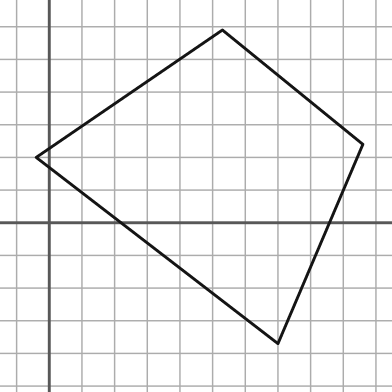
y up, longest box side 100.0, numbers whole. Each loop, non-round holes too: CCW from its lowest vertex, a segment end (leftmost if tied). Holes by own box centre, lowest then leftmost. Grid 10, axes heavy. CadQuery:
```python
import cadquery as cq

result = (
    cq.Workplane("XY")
    .moveTo(70.0, -37.0)
    .lineTo(96.0, 24.0)
    .lineTo(53.0, 59.0)
    .lineTo(-4.0, 20.0)
    .close()
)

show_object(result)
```